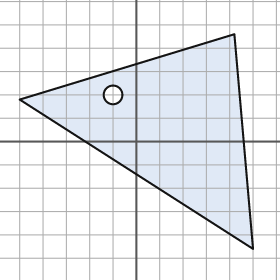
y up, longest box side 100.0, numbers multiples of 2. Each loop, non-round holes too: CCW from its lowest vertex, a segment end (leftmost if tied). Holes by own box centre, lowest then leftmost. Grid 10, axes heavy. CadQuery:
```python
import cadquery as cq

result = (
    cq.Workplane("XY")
    .moveTo(50.0, -46.0)
    .lineTo(42.0, 46.0)
    .lineTo(-50.0, 18.0)
    .close()
    .moveTo(-10.0, 20.0)
    .circle(4.0)
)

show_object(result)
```